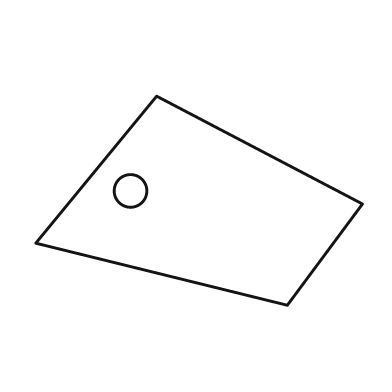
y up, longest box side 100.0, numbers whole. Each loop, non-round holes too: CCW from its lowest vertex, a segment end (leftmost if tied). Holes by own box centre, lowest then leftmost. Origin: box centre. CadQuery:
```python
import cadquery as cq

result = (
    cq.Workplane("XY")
    .moveTo(27.0, -32.0)
    .lineTo(50.0, -1.0)
    .lineTo(-13.0, 32.0)
    .lineTo(-50.0, -13.0)
    .close()
    .moveTo(-21.0, 3.0)
    .circle(5.0)
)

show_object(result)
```